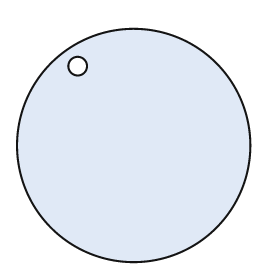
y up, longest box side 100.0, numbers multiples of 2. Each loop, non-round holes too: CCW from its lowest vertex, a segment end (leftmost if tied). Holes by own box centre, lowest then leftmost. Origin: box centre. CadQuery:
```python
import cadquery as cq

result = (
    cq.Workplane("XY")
    .moveTo(0.0, 0.0)
    .circle(50.0)
    .moveTo(-24.0, 34.0)
    .circle(4.0)
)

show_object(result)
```